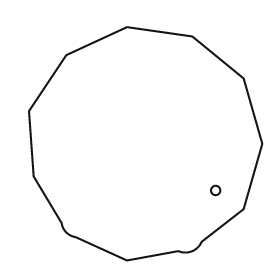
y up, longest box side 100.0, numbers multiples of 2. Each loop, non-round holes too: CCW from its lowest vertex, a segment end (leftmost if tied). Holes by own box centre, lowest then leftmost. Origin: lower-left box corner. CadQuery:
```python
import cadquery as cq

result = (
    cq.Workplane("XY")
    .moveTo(42.0, 0.0)
    .lineTo(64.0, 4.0)
    .threePointArc((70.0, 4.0), (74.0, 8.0))
    .lineTo(92.0, 22.0)
    .lineTo(100.0, 50.0)
    .lineTo(92.0, 78.0)
    .lineTo(70.0, 96.0)
    .lineTo(42.0, 100.0)
    .lineTo(16.0, 88.0)
    .lineTo(0.0, 64.0)
    .lineTo(2.0, 36.0)
    .lineTo(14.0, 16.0)
    .threePointArc((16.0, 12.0), (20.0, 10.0))
    .close()
    .moveTo(80.0, 30.0)
    .circle(2.0)
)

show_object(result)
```